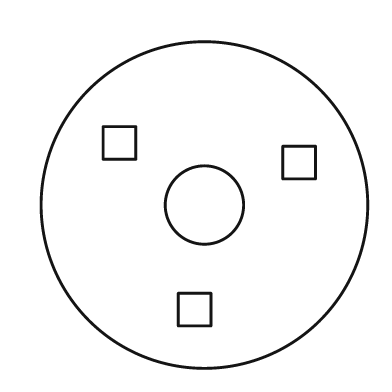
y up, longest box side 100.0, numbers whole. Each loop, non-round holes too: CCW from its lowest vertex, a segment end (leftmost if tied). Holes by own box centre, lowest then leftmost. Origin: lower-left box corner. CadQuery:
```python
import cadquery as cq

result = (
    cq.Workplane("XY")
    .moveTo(50.0, 50.0)
    .circle(50.0)
    .moveTo(42.0, 13.0)
    .lineTo(52.0, 13.0)
    .lineTo(52.0, 23.0)
    .lineTo(42.0, 23.0)
    .close()
    .moveTo(50.0, 50.0)
    .circle(12.0)
    .moveTo(74.0, 58.0)
    .lineTo(84.0, 58.0)
    .lineTo(84.0, 68.0)
    .lineTo(74.0, 68.0)
    .close()
    .moveTo(19.0, 64.0)
    .lineTo(29.0, 64.0)
    .lineTo(29.0, 74.0)
    .lineTo(19.0, 74.0)
    .close()
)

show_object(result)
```